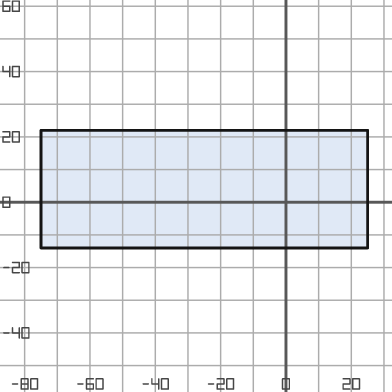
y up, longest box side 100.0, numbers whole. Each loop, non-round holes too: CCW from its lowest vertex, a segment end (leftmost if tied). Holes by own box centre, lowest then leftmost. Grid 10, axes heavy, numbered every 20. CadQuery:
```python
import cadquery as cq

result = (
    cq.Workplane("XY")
    .moveTo(-75.0, -14.0)
    .lineTo(25.0, -14.0)
    .lineTo(25.0, 22.0)
    .lineTo(-75.0, 22.0)
    .close()
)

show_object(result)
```